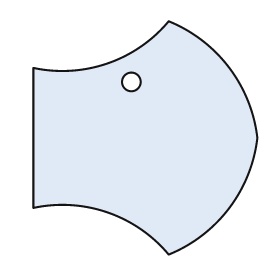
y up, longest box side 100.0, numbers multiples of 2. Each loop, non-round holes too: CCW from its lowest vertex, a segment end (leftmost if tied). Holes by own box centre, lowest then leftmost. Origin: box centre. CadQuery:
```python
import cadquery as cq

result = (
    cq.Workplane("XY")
    .moveTo(10.0, -50.0)
    .threePointArc((36.0, -30.0), (48.0, 0.0))
    .threePointArc((36.0, 30.0), (10.0, 50.0))
    .threePointArc((-16.0, 32.0), (-48.0, 30.0))
    .lineTo(-48.0, -30.0)
    .threePointArc((-16.0, -32.0), (10.0, -50.0))
    .close()
    .moveTo(-6.0, 24.0)
    .circle(4.0)
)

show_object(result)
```